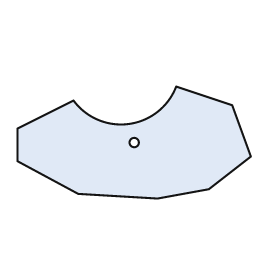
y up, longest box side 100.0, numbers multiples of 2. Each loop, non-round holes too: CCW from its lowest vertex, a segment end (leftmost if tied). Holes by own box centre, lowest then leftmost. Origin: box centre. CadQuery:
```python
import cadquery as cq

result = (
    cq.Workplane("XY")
    .moveTo(10.0, -24.0)
    .lineTo(32.0, -20.0)
    .lineTo(50.0, -6.0)
    .lineTo(42.0, 16.0)
    .lineTo(18.0, 24.0)
    .threePointArc((-2.0, 8.0), (-26.0, 18.0))
    .lineTo(-50.0, 6.0)
    .lineTo(-50.0, -8.0)
    .lineTo(-24.0, -22.0)
    .close()
    .moveTo(0.0, 0.0)
    .circle(2.0)
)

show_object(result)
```